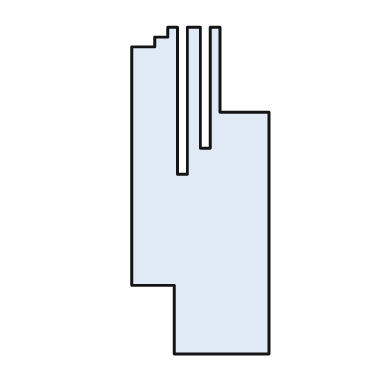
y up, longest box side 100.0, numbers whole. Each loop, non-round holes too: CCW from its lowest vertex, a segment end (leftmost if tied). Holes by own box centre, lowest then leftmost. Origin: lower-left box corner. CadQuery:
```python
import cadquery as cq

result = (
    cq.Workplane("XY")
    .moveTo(13.0, 0.0)
    .lineTo(42.0, 0.0)
    .lineTo(42.0, 74.0)
    .lineTo(27.0, 74.0)
    .lineTo(27.0, 100.0)
    .lineTo(24.0, 100.0)
    .lineTo(24.0, 63.0)
    .lineTo(21.0, 63.0)
    .lineTo(21.0, 100.0)
    .lineTo(17.0, 100.0)
    .lineTo(17.0, 55.0)
    .lineTo(14.0, 55.0)
    .lineTo(14.0, 100.0)
    .lineTo(11.0, 100.0)
    .lineTo(11.0, 97.0)
    .lineTo(7.0, 97.0)
    .lineTo(7.0, 94.0)
    .lineTo(0.0, 94.0)
    .lineTo(0.0, 21.0)
    .lineTo(13.0, 21.0)
    .close()
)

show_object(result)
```